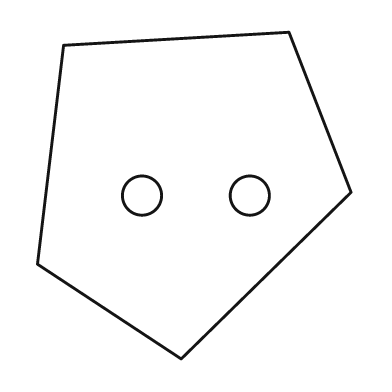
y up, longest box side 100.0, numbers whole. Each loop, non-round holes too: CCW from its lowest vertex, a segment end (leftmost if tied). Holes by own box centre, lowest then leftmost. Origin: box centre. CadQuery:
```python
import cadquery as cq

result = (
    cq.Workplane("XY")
    .moveTo(-4.0, -50.0)
    .lineTo(48.0, 1.0)
    .lineTo(29.0, 50.0)
    .lineTo(-40.0, 46.0)
    .lineTo(-48.0, -21.0)
    .close()
    .moveTo(-16.0, 0.0)
    .circle(6.0)
    .moveTo(17.0, 0.0)
    .circle(6.0)
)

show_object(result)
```